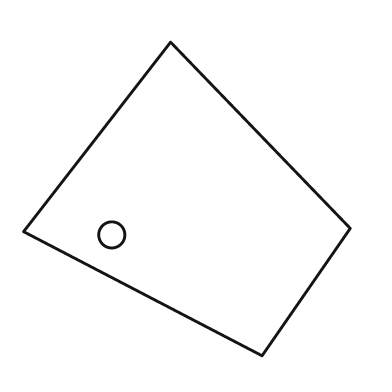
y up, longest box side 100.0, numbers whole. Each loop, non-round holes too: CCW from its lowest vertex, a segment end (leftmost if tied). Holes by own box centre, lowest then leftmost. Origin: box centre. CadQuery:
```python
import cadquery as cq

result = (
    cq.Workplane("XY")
    .moveTo(23.0, -48.0)
    .lineTo(50.0, -9.0)
    .lineTo(-5.0, 48.0)
    .lineTo(-50.0, -10.0)
    .close()
    .moveTo(-23.0, -11.0)
    .circle(4.0)
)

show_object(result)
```